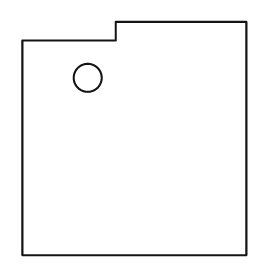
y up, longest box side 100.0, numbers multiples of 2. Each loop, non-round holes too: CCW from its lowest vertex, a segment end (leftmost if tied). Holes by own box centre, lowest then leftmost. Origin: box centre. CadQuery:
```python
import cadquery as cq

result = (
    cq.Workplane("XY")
    .moveTo(-48.0, -50.0)
    .lineTo(48.0, -50.0)
    .lineTo(48.0, 50.0)
    .lineTo(-8.0, 50.0)
    .lineTo(-8.0, 42.0)
    .lineTo(-48.0, 42.0)
    .close()
    .moveTo(-20.0, 26.0)
    .circle(6.0)
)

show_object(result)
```